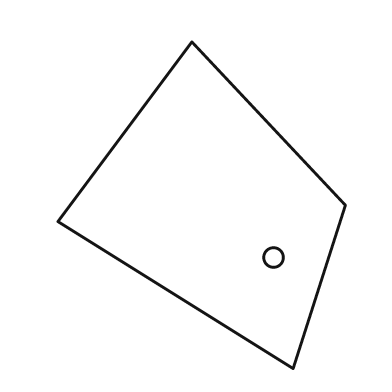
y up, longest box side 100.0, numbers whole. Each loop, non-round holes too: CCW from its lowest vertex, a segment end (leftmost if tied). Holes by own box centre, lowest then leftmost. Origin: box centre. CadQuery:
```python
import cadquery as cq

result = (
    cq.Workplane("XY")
    .moveTo(28.0, -50.0)
    .lineTo(44.0, 0.0)
    .lineTo(-3.0, 50.0)
    .lineTo(-44.0, -5.0)
    .close()
    .moveTo(22.0, -16.0)
    .circle(3.0)
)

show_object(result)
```